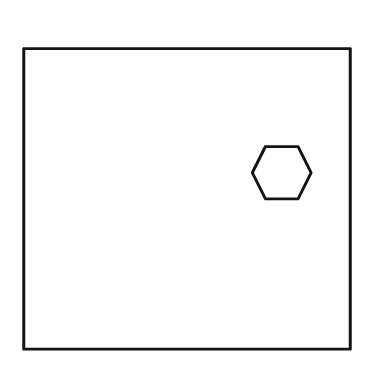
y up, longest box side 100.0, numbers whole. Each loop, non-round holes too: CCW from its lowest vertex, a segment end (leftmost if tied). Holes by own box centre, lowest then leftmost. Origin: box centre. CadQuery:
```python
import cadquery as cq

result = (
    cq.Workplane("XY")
    .moveTo(-50.0, -46.0)
    .lineTo(50.0, -46.0)
    .lineTo(50.0, 46.0)
    .lineTo(-50.0, 46.0)
    .close()
    .moveTo(24.0, 0.0)
    .lineTo(34.0, 0.0)
    .lineTo(38.0, 8.0)
    .lineTo(34.0, 16.0)
    .lineTo(24.0, 16.0)
    .lineTo(20.0, 8.0)
    .close()
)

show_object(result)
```